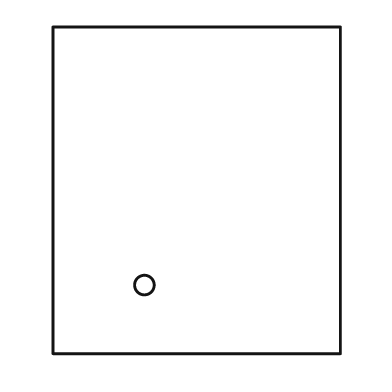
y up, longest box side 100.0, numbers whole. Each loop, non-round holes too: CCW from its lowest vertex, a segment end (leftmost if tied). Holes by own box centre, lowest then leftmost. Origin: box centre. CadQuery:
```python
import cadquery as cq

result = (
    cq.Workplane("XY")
    .moveTo(-44.0, -50.0)
    .lineTo(44.0, -50.0)
    .lineTo(44.0, 50.0)
    .lineTo(-44.0, 50.0)
    .close()
    .moveTo(-16.0, -29.0)
    .circle(3.0)
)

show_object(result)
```